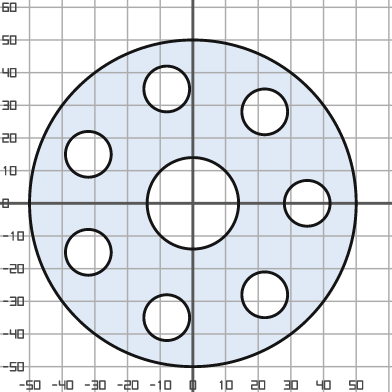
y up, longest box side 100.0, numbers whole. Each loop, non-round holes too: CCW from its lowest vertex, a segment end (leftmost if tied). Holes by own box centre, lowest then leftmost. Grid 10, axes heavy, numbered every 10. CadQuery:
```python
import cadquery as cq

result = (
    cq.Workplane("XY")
    .moveTo(0.0, 0.0)
    .circle(50.0)
    .moveTo(-8.0, -35.0)
    .circle(7.0)
    .moveTo(22.0, -28.0)
    .circle(7.0)
    .moveTo(-32.0, -15.0)
    .circle(7.0)
    .moveTo(0.0, 0.0)
    .circle(14.0)
    .moveTo(35.0, 0.0)
    .circle(7.0)
    .moveTo(-32.0, 15.0)
    .circle(7.0)
    .moveTo(22.0, 28.0)
    .circle(7.0)
    .moveTo(-8.0, 35.0)
    .circle(7.0)
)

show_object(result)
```